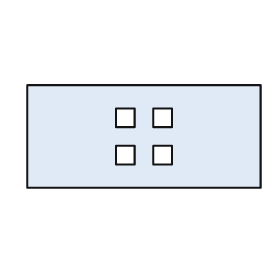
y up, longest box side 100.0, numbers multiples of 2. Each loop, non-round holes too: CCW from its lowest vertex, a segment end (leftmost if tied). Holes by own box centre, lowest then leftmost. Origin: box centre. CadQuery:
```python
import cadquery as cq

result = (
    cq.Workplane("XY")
    .moveTo(-50.0, -22.0)
    .lineTo(50.0, -22.0)
    .lineTo(50.0, 22.0)
    .lineTo(-50.0, 22.0)
    .close()
    .moveTo(-12.0, -12.0)
    .lineTo(-4.0, -12.0)
    .lineTo(-4.0, -4.0)
    .lineTo(-12.0, -4.0)
    .close()
    .moveTo(4.0, -12.0)
    .lineTo(12.0, -12.0)
    .lineTo(12.0, -4.0)
    .lineTo(4.0, -4.0)
    .close()
    .moveTo(-12.0, 4.0)
    .lineTo(-4.0, 4.0)
    .lineTo(-4.0, 12.0)
    .lineTo(-12.0, 12.0)
    .close()
    .moveTo(4.0, 4.0)
    .lineTo(12.0, 4.0)
    .lineTo(12.0, 12.0)
    .lineTo(4.0, 12.0)
    .close()
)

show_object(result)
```